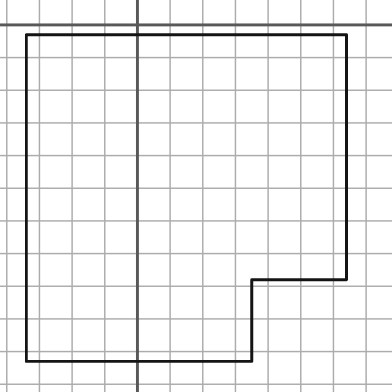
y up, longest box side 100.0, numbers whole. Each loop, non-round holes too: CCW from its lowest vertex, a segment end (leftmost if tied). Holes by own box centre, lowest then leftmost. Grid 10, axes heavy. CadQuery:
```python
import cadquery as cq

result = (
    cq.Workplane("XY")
    .moveTo(-34.0, -103.0)
    .lineTo(35.0, -103.0)
    .lineTo(35.0, -78.0)
    .lineTo(64.0, -78.0)
    .lineTo(64.0, -3.0)
    .lineTo(-34.0, -3.0)
    .close()
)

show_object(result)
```